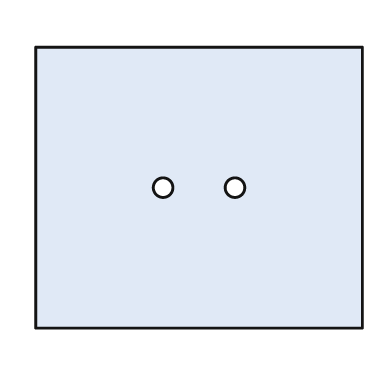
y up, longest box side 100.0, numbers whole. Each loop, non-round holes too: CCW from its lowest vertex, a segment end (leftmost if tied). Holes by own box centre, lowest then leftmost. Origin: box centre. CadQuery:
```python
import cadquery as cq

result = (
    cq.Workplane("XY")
    .moveTo(-50.0, -43.0)
    .lineTo(50.0, -43.0)
    .lineTo(50.0, 43.0)
    .lineTo(-50.0, 43.0)
    .close()
    .moveTo(-11.0, 0.0)
    .circle(3.0)
    .moveTo(11.0, 0.0)
    .circle(3.0)
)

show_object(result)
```